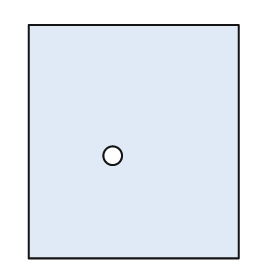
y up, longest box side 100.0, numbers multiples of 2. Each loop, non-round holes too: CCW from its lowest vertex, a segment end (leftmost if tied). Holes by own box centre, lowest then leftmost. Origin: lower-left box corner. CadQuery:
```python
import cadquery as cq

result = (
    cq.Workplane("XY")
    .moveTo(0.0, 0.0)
    .lineTo(90.0, 0.0)
    .lineTo(90.0, 100.0)
    .lineTo(0.0, 100.0)
    .close()
    .moveTo(36.0, 44.0)
    .circle(4.0)
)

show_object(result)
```